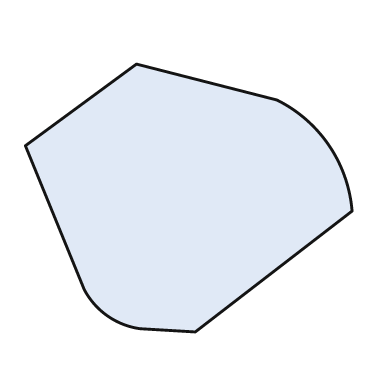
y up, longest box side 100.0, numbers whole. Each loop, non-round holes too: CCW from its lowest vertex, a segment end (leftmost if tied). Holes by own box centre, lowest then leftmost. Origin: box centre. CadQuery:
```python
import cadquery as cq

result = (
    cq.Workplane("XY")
    .moveTo(2.0, -41.0)
    .lineTo(50.0, -4.0)
    .threePointArc((43.0, 16.0), (27.0, 30.0))
    .lineTo(-16.0, 41.0)
    .lineTo(-50.0, 16.0)
    .lineTo(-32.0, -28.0)
    .threePointArc((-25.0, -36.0), (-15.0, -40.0))
    .close()
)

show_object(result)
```